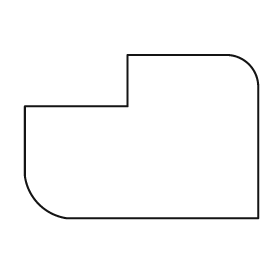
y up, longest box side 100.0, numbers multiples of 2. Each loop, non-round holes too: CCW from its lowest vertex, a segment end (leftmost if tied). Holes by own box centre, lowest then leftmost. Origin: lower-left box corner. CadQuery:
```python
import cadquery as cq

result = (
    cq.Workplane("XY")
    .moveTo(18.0, 0.0)
    .lineTo(100.0, 0.0)
    .lineTo(100.0, 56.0)
    .threePointArc((96.0, 66.0), (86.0, 70.0))
    .lineTo(44.0, 70.0)
    .lineTo(44.0, 48.0)
    .lineTo(0.0, 48.0)
    .lineTo(0.0, 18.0)
    .threePointArc((6.0, 6.0), (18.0, 0.0))
    .close()
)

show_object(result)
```